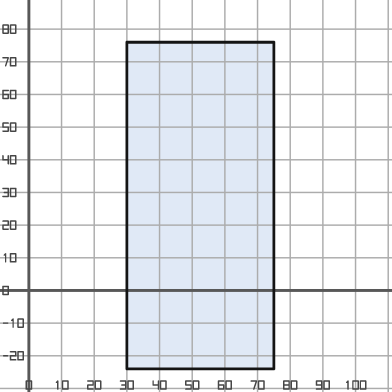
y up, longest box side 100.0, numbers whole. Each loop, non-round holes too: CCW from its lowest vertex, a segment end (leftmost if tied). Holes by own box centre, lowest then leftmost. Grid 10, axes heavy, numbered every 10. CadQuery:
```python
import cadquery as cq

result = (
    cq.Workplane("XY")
    .moveTo(30.0, -24.0)
    .lineTo(75.0, -24.0)
    .lineTo(75.0, 76.0)
    .lineTo(30.0, 76.0)
    .close()
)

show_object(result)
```